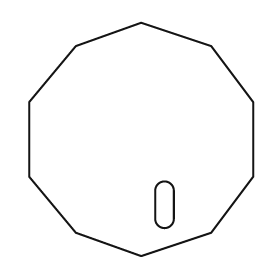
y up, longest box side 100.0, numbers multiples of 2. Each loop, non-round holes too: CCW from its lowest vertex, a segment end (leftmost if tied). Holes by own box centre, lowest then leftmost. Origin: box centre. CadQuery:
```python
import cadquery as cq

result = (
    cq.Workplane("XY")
    .moveTo(0.0, -50.0)
    .lineTo(30.0, -40.0)
    .lineTo(48.0, -16.0)
    .lineTo(48.0, 16.0)
    .lineTo(30.0, 40.0)
    .lineTo(0.0, 50.0)
    .lineTo(-28.0, 40.0)
    .lineTo(-48.0, 16.0)
    .lineTo(-48.0, -16.0)
    .lineTo(-28.0, -40.0)
    .close()
    .moveTo(6.0, -34.0)
    .threePointArc((10.0, -38.0), (14.0, -34.0))
    .lineTo(14.0, -22.0)
    .threePointArc((10.0, -18.0), (6.0, -22.0))
    .close()
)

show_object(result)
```